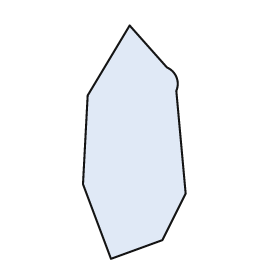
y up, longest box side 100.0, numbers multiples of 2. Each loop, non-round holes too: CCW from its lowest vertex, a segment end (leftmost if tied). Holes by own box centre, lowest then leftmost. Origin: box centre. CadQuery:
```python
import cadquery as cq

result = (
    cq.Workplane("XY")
    .moveTo(-10.0, -50.0)
    .lineTo(12.0, -42.0)
    .lineTo(22.0, -22.0)
    .lineTo(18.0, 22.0)
    .threePointArc((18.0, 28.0), (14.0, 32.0))
    .lineTo(-2.0, 50.0)
    .lineTo(-20.0, 20.0)
    .lineTo(-22.0, -18.0)
    .close()
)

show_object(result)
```